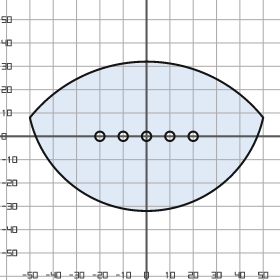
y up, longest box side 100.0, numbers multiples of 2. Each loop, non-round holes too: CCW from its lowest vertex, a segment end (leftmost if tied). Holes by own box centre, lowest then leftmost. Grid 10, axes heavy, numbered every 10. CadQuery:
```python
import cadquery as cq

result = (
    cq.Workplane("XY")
    .moveTo(-50.0, 8.0)
    .threePointArc((0.0, -32.0), (50.0, 8.0))
    .threePointArc((0.0, 32.0), (-50.0, 8.0))
    .close()
    .moveTo(-20.0, 0.0)
    .circle(2.0)
    .moveTo(-10.0, 0.0)
    .circle(2.0)
    .moveTo(0.0, 0.0)
    .circle(2.0)
    .moveTo(10.0, 0.0)
    .circle(2.0)
    .moveTo(20.0, 0.0)
    .circle(2.0)
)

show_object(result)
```